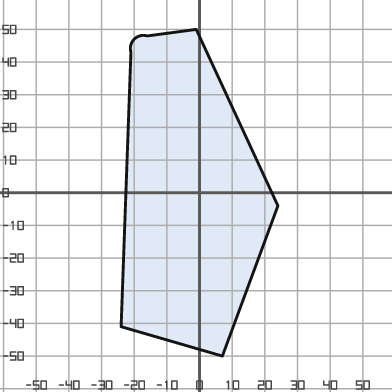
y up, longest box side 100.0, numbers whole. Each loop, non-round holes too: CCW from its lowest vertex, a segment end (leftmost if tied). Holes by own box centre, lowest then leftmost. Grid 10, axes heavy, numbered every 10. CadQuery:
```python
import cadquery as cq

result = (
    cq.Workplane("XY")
    .moveTo(7.0, -50.0)
    .lineTo(24.0, -4.0)
    .lineTo(-1.0, 50.0)
    .lineTo(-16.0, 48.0)
    .threePointArc((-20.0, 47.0), (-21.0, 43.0))
    .lineTo(-24.0, -41.0)
    .close()
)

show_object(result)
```